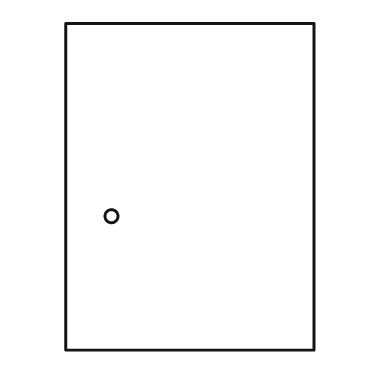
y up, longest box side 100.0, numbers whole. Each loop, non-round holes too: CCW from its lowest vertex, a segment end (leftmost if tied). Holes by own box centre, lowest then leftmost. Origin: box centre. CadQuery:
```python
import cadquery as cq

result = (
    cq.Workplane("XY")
    .moveTo(-38.0, -50.0)
    .lineTo(38.0, -50.0)
    .lineTo(38.0, 50.0)
    .lineTo(-38.0, 50.0)
    .close()
    .moveTo(-24.0, -9.0)
    .circle(2.0)
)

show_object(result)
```